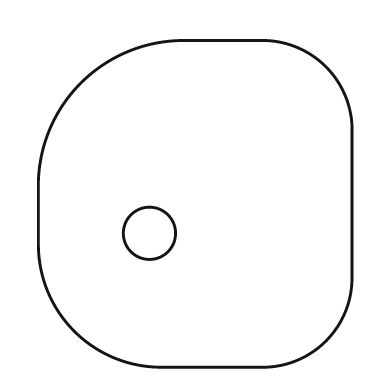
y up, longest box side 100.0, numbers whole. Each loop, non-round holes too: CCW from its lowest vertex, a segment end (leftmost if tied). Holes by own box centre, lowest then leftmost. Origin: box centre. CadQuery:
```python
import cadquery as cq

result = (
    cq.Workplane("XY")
    .moveTo(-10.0, -50.0)
    .lineTo(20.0, -50.0)
    .threePointArc((40.0, -42.0), (48.0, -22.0))
    .lineTo(48.0, 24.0)
    .threePointArc((40.0, 42.0), (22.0, 50.0))
    .lineTo(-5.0, 50.0)
    .threePointArc((-35.0, 37.0), (-48.0, 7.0))
    .lineTo(-48.0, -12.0)
    .threePointArc((-37.0, -39.0), (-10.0, -50.0))
    .close()
    .moveTo(-14.0, -9.0)
    .circle(8.0)
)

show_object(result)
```